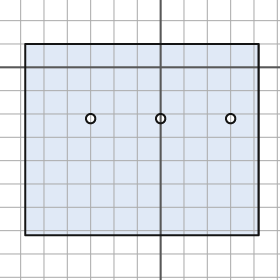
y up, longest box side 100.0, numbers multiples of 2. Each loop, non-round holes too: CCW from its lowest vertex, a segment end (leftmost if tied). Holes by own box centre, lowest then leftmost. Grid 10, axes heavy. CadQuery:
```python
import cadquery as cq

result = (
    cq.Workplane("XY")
    .moveTo(-58.0, -72.0)
    .lineTo(42.0, -72.0)
    .lineTo(42.0, 10.0)
    .lineTo(-58.0, 10.0)
    .close()
    .moveTo(-30.0, -22.0)
    .circle(2.0)
    .moveTo(0.0, -22.0)
    .circle(2.0)
    .moveTo(30.0, -22.0)
    .circle(2.0)
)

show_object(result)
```